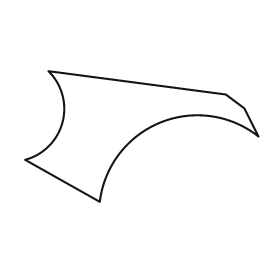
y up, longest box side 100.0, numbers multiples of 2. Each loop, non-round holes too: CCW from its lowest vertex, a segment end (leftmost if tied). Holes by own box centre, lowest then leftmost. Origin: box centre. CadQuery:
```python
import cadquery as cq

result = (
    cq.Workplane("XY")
    .moveTo(-18.0, -28.0)
    .threePointArc((8.0, 6.0), (50.0, 0.0))
    .lineTo(44.0, 12.0)
    .lineTo(36.0, 18.0)
    .lineTo(-40.0, 28.0)
    .threePointArc((-34.0, 6.0), (-50.0, -10.0))
    .close()
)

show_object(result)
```